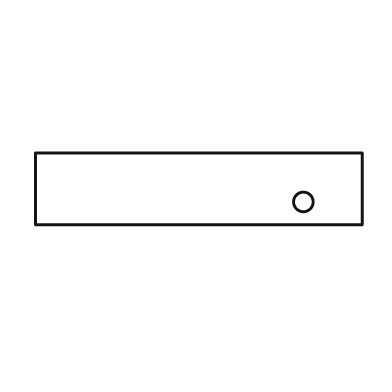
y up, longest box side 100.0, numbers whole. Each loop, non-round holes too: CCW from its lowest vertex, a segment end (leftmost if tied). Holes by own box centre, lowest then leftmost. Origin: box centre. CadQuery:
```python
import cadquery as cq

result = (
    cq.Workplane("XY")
    .moveTo(-50.0, -11.0)
    .lineTo(50.0, -11.0)
    .lineTo(50.0, 11.0)
    .lineTo(-50.0, 11.0)
    .close()
    .moveTo(32.0, -4.0)
    .circle(3.0)
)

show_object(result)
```